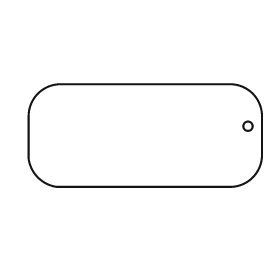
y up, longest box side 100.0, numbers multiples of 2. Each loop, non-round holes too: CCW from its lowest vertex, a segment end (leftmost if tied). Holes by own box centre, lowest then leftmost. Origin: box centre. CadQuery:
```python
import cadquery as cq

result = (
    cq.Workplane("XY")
    .moveTo(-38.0, -22.0)
    .lineTo(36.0, -22.0)
    .threePointArc((46.0, -18.0), (50.0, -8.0))
    .lineTo(50.0, 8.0)
    .threePointArc((46.0, 18.0), (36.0, 22.0))
    .lineTo(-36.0, 22.0)
    .threePointArc((-46.0, 18.0), (-50.0, 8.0))
    .lineTo(-50.0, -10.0)
    .threePointArc((-46.0, -18.0), (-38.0, -22.0))
    .close()
    .moveTo(44.0, 4.0)
    .circle(2.0)
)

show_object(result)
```